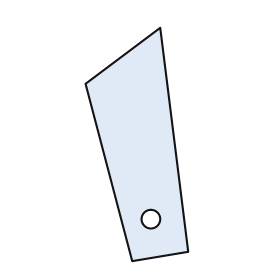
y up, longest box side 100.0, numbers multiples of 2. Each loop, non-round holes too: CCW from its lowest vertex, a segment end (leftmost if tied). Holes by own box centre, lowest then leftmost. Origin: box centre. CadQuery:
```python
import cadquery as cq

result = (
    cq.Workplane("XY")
    .moveTo(-2.0, -50.0)
    .lineTo(22.0, -46.0)
    .lineTo(10.0, 50.0)
    .lineTo(-22.0, 26.0)
    .close()
    .moveTo(6.0, -32.0)
    .circle(4.0)
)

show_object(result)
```